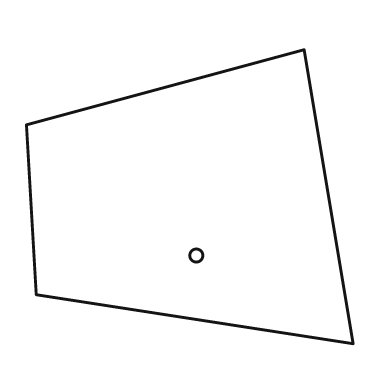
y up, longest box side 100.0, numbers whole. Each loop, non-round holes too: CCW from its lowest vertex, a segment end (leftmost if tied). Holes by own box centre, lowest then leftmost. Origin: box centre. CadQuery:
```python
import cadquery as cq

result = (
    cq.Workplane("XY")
    .moveTo(50.0, -45.0)
    .lineTo(35.0, 45.0)
    .lineTo(-50.0, 22.0)
    .lineTo(-47.0, -30.0)
    .close()
    .moveTo(2.0, -18.0)
    .circle(2.0)
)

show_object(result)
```